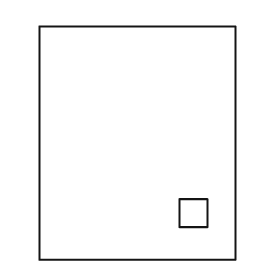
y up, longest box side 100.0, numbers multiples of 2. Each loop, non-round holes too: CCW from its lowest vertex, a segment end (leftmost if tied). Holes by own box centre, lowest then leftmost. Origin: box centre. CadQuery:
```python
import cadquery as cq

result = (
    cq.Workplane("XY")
    .moveTo(-42.0, -50.0)
    .lineTo(42.0, -50.0)
    .lineTo(42.0, 50.0)
    .lineTo(-42.0, 50.0)
    .close()
    .moveTo(18.0, -36.0)
    .lineTo(30.0, -36.0)
    .lineTo(30.0, -24.0)
    .lineTo(18.0, -24.0)
    .close()
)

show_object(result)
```